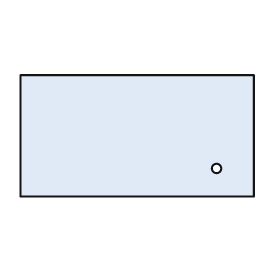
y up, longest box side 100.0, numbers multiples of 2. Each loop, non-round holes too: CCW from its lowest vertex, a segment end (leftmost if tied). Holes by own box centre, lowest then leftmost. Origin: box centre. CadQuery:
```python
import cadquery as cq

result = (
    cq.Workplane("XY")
    .moveTo(-50.0, -26.0)
    .lineTo(50.0, -26.0)
    .lineTo(50.0, 26.0)
    .lineTo(-50.0, 26.0)
    .close()
    .moveTo(34.0, -14.0)
    .circle(2.0)
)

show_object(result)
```